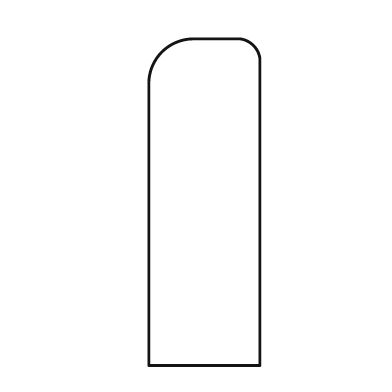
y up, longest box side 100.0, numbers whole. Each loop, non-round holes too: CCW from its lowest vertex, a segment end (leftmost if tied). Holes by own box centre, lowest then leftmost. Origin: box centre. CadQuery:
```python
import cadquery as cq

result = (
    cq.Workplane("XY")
    .moveTo(-17.0, -50.0)
    .lineTo(17.0, -50.0)
    .lineTo(17.0, 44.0)
    .threePointArc((15.0, 48.0), (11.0, 50.0))
    .lineTo(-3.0, 50.0)
    .threePointArc((-13.0, 46.0), (-17.0, 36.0))
    .close()
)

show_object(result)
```